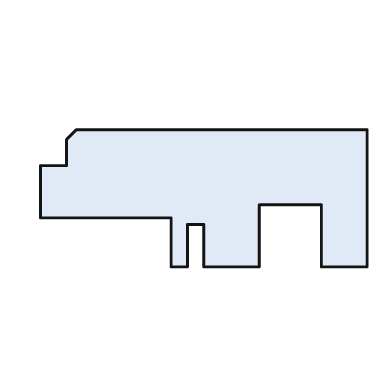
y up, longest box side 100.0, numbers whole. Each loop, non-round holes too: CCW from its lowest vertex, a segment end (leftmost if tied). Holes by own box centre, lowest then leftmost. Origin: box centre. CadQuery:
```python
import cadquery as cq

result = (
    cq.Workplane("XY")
    .moveTo(-10.0, -21.0)
    .lineTo(-5.0, -21.0)
    .lineTo(-5.0, -8.0)
    .lineTo(0.0, -8.0)
    .lineTo(0.0, -21.0)
    .lineTo(17.0, -21.0)
    .lineTo(17.0, -2.0)
    .lineTo(36.0, -2.0)
    .lineTo(36.0, -21.0)
    .lineTo(50.0, -21.0)
    .lineTo(50.0, 21.0)
    .lineTo(-39.0, 21.0)
    .lineTo(-42.0, 18.0)
    .lineTo(-42.0, 10.0)
    .lineTo(-50.0, 10.0)
    .lineTo(-50.0, -6.0)
    .lineTo(-10.0, -6.0)
    .close()
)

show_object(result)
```